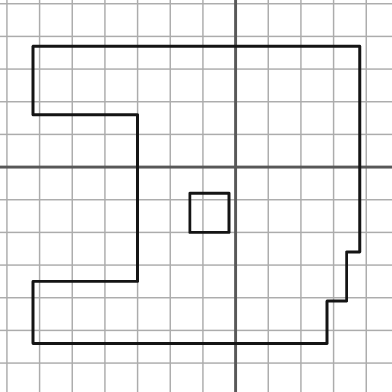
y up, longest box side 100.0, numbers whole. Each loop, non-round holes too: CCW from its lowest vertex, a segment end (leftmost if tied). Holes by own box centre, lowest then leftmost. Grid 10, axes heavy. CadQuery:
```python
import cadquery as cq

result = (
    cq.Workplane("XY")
    .moveTo(-62.0, -54.0)
    .lineTo(28.0, -54.0)
    .lineTo(28.0, -41.0)
    .lineTo(34.0, -41.0)
    .lineTo(34.0, -26.0)
    .lineTo(38.0, -26.0)
    .lineTo(38.0, 37.0)
    .lineTo(-62.0, 37.0)
    .lineTo(-62.0, 16.0)
    .lineTo(-30.0, 16.0)
    .lineTo(-30.0, -35.0)
    .lineTo(-62.0, -35.0)
    .close()
    .moveTo(-14.0, -20.0)
    .lineTo(-2.0, -20.0)
    .lineTo(-2.0, -8.0)
    .lineTo(-14.0, -8.0)
    .close()
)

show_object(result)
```